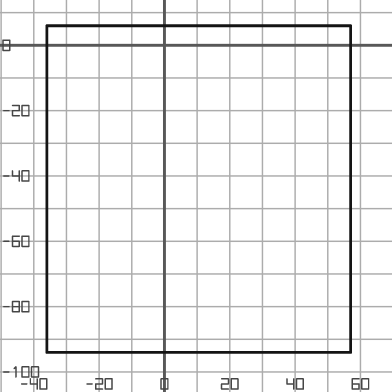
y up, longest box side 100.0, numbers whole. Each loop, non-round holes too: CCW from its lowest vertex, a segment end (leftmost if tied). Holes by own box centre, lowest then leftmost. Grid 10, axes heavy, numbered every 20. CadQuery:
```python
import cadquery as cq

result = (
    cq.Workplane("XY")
    .moveTo(-36.0, -94.0)
    .lineTo(57.0, -94.0)
    .lineTo(57.0, 6.0)
    .lineTo(-36.0, 6.0)
    .close()
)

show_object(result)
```